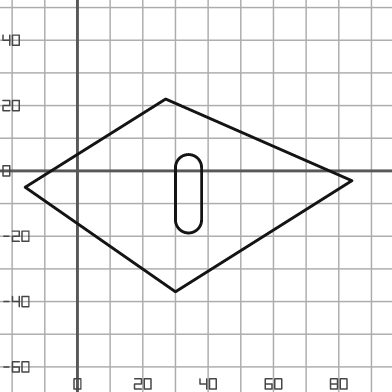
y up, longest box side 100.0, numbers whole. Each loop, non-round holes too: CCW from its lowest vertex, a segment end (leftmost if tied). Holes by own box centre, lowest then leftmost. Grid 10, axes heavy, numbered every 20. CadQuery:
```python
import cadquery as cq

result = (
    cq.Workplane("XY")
    .moveTo(30.0, -37.0)
    .lineTo(84.0, -3.0)
    .lineTo(27.0, 22.0)
    .lineTo(-16.0, -5.0)
    .close()
    .moveTo(30.0, -15.0)
    .threePointArc((34.0, -19.0), (38.0, -15.0))
    .lineTo(38.0, 1.0)
    .threePointArc((34.0, 5.0), (30.0, 1.0))
    .close()
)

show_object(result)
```